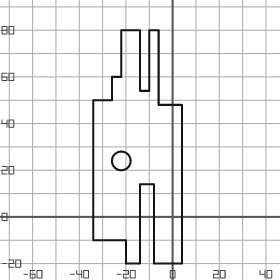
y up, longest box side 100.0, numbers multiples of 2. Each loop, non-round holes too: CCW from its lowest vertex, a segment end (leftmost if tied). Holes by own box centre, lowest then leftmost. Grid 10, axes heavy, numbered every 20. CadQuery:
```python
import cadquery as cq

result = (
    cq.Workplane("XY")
    .moveTo(-20.0, -20.0)
    .lineTo(-14.0, -20.0)
    .lineTo(-14.0, 14.0)
    .lineTo(-8.0, 14.0)
    .lineTo(-8.0, -20.0)
    .lineTo(4.0, -20.0)
    .lineTo(4.0, 48.0)
    .lineTo(-6.0, 48.0)
    .lineTo(-6.0, 80.0)
    .lineTo(-10.0, 80.0)
    .lineTo(-10.0, 54.0)
    .lineTo(-14.0, 54.0)
    .lineTo(-14.0, 80.0)
    .lineTo(-22.0, 80.0)
    .lineTo(-22.0, 60.0)
    .lineTo(-26.0, 60.0)
    .lineTo(-26.0, 50.0)
    .lineTo(-34.0, 50.0)
    .lineTo(-34.0, -10.0)
    .lineTo(-20.0, -10.0)
    .close()
    .moveTo(-22.0, 24.0)
    .circle(4.0)
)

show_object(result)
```